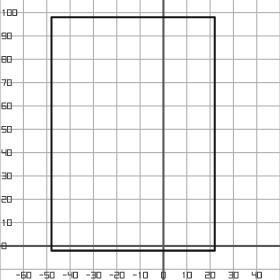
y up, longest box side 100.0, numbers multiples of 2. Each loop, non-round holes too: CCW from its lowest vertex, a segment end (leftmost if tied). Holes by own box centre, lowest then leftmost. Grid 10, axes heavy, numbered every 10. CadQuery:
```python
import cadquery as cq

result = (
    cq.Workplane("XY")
    .moveTo(-48.0, -2.0)
    .lineTo(22.0, -2.0)
    .lineTo(22.0, 98.0)
    .lineTo(-48.0, 98.0)
    .close()
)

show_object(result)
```